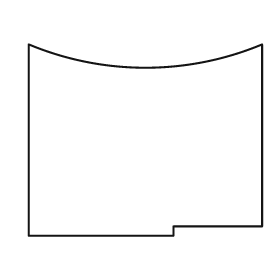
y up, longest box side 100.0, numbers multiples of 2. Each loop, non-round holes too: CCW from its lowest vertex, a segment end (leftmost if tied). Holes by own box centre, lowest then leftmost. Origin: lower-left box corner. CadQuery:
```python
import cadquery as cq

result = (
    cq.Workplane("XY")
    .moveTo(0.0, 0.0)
    .lineTo(62.0, 0.0)
    .lineTo(62.0, 4.0)
    .lineTo(100.0, 4.0)
    .lineTo(100.0, 82.0)
    .threePointArc((50.0, 72.0), (0.0, 82.0))
    .close()
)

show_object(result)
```